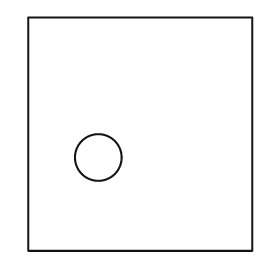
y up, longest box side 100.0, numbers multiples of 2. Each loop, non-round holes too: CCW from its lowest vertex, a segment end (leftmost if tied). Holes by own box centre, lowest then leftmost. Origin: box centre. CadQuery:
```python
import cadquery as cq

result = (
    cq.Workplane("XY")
    .moveTo(-48.0, -50.0)
    .lineTo(48.0, -50.0)
    .lineTo(48.0, 50.0)
    .lineTo(-48.0, 50.0)
    .close()
    .moveTo(-18.0, -10.0)
    .circle(10.0)
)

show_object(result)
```